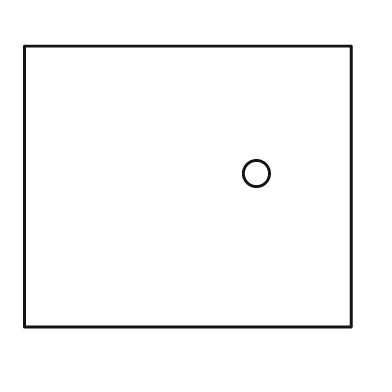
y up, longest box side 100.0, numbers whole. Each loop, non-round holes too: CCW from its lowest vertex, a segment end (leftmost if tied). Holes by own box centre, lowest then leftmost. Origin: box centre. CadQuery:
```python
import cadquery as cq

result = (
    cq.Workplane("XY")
    .moveTo(-50.0, -43.0)
    .lineTo(50.0, -43.0)
    .lineTo(50.0, 43.0)
    .lineTo(-50.0, 43.0)
    .close()
    .moveTo(21.0, 4.0)
    .circle(4.0)
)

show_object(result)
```